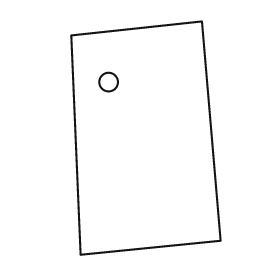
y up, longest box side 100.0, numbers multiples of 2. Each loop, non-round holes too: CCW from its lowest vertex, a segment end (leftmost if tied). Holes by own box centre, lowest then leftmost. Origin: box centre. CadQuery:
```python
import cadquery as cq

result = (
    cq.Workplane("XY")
    .moveTo(-28.0, -50.0)
    .lineTo(32.0, -44.0)
    .lineTo(24.0, 50.0)
    .lineTo(-32.0, 44.0)
    .close()
    .moveTo(-16.0, 24.0)
    .circle(4.0)
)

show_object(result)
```